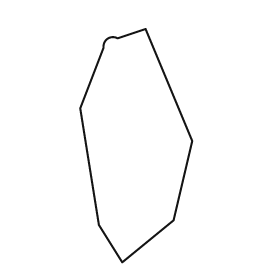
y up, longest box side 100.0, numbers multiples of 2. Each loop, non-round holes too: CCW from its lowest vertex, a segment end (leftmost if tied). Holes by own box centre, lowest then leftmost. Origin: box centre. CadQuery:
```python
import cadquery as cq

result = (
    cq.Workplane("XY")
    .moveTo(-6.0, -50.0)
    .lineTo(16.0, -32.0)
    .lineTo(24.0, 2.0)
    .lineTo(4.0, 50.0)
    .lineTo(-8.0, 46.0)
    .threePointArc((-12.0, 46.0), (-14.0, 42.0))
    .lineTo(-24.0, 16.0)
    .lineTo(-16.0, -34.0)
    .close()
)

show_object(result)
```